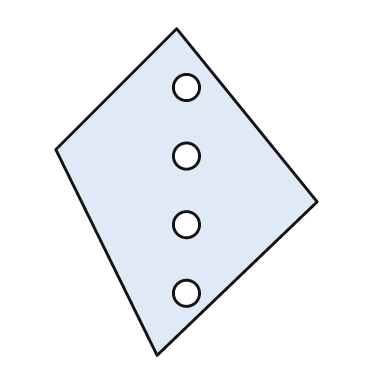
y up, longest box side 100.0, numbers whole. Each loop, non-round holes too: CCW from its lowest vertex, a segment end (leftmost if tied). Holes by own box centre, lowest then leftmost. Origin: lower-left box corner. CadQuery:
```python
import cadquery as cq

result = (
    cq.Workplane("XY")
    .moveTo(31.0, 0.0)
    .lineTo(80.0, 47.0)
    .lineTo(37.0, 100.0)
    .lineTo(0.0, 63.0)
    .close()
    .moveTo(40.0, 19.0)
    .circle(4.0)
    .moveTo(40.0, 40.0)
    .circle(4.0)
    .moveTo(40.0, 61.0)
    .circle(4.0)
    .moveTo(40.0, 82.0)
    .circle(4.0)
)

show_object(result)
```